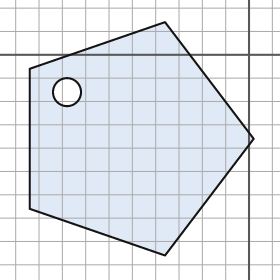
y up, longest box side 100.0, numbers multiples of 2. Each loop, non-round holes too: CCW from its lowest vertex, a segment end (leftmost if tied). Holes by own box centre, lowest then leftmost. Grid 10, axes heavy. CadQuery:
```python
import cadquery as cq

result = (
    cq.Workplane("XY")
    .moveTo(-36.0, -86.0)
    .lineTo(2.0, -36.0)
    .lineTo(-36.0, 14.0)
    .lineTo(-94.0, -6.0)
    .lineTo(-94.0, -66.0)
    .close()
    .moveTo(-78.0, -16.0)
    .circle(6.0)
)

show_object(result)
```